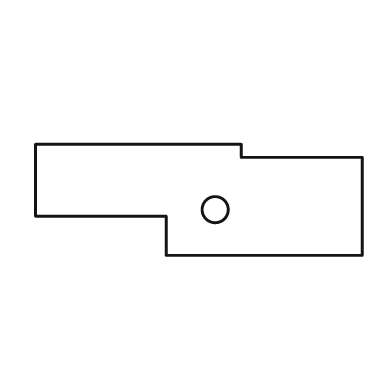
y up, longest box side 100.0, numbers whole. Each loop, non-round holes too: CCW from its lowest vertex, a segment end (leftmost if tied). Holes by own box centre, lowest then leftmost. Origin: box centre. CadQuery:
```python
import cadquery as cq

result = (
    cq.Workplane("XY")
    .moveTo(-10.0, -17.0)
    .lineTo(50.0, -17.0)
    .lineTo(50.0, 13.0)
    .lineTo(13.0, 13.0)
    .lineTo(13.0, 17.0)
    .lineTo(-50.0, 17.0)
    .lineTo(-50.0, -5.0)
    .lineTo(-10.0, -5.0)
    .close()
    .moveTo(5.0, -3.0)
    .circle(4.0)
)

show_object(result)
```